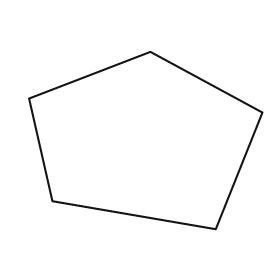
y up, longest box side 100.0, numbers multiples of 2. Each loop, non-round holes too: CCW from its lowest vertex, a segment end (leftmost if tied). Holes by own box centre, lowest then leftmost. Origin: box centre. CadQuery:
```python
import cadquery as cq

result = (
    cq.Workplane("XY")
    .moveTo(30.0, -38.0)
    .lineTo(50.0, 12.0)
    .lineTo(2.0, 38.0)
    .lineTo(-50.0, 18.0)
    .lineTo(-40.0, -26.0)
    .close()
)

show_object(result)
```